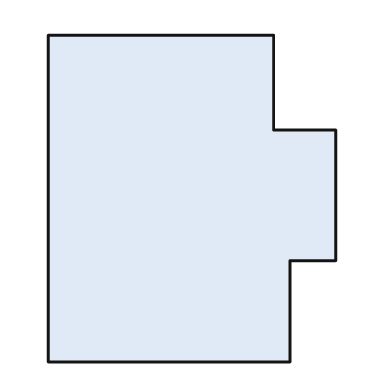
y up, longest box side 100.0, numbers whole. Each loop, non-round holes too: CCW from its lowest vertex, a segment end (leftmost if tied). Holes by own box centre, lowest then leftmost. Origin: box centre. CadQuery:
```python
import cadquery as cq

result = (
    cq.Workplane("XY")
    .moveTo(-44.0, -50.0)
    .lineTo(30.0, -50.0)
    .lineTo(30.0, -19.0)
    .lineTo(44.0, -19.0)
    .lineTo(44.0, 21.0)
    .lineTo(25.0, 21.0)
    .lineTo(25.0, 50.0)
    .lineTo(-44.0, 50.0)
    .close()
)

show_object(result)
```